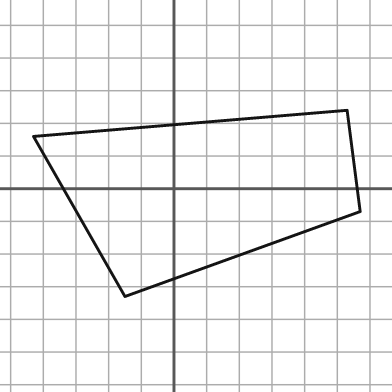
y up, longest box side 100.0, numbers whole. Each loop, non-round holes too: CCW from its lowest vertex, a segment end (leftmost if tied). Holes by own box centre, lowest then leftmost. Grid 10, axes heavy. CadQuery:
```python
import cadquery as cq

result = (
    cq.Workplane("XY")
    .moveTo(-15.0, -33.0)
    .lineTo(57.0, -7.0)
    .lineTo(53.0, 24.0)
    .lineTo(-43.0, 16.0)
    .close()
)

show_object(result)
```